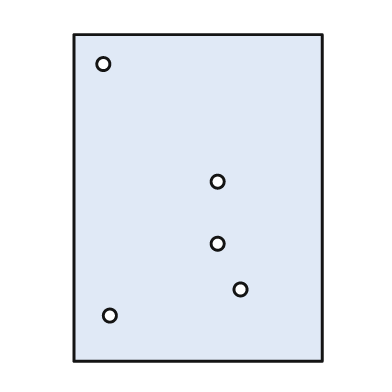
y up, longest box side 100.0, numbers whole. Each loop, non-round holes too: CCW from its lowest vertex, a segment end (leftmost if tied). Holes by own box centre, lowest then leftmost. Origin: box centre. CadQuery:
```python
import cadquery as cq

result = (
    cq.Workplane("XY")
    .moveTo(-38.0, -50.0)
    .lineTo(38.0, -50.0)
    .lineTo(38.0, 50.0)
    .lineTo(-38.0, 50.0)
    .close()
    .moveTo(-27.0, -36.0)
    .circle(2.0)
    .moveTo(13.0, -28.0)
    .circle(2.0)
    .moveTo(6.0, -14.0)
    .circle(2.0)
    .moveTo(6.0, 5.0)
    .circle(2.0)
    .moveTo(-29.0, 41.0)
    .circle(2.0)
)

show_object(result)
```